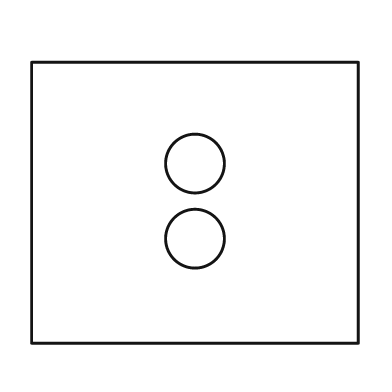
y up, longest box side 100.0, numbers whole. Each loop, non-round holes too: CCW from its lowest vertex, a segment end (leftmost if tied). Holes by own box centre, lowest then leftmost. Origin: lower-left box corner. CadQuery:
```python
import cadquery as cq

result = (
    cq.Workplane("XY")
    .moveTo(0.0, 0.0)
    .lineTo(100.0, 0.0)
    .lineTo(100.0, 86.0)
    .lineTo(0.0, 86.0)
    .close()
    .moveTo(50.0, 32.0)
    .circle(9.0)
    .moveTo(50.0, 55.0)
    .circle(9.0)
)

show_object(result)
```